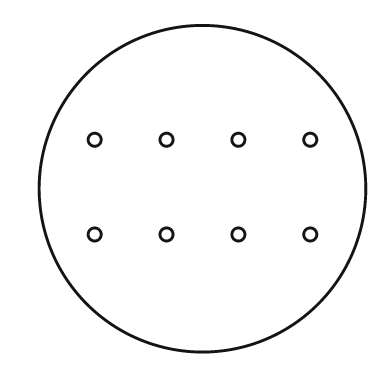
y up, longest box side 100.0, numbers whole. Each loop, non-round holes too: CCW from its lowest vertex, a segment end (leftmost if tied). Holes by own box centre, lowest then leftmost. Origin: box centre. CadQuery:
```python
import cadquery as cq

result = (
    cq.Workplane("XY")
    .moveTo(0.0, 0.0)
    .circle(50.0)
    .moveTo(-33.0, -14.0)
    .circle(2.0)
    .moveTo(-11.0, -14.0)
    .circle(2.0)
    .moveTo(11.0, -14.0)
    .circle(2.0)
    .moveTo(33.0, -14.0)
    .circle(2.0)
    .moveTo(-33.0, 15.0)
    .circle(2.0)
    .moveTo(-11.0, 15.0)
    .circle(2.0)
    .moveTo(11.0, 15.0)
    .circle(2.0)
    .moveTo(33.0, 15.0)
    .circle(2.0)
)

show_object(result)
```